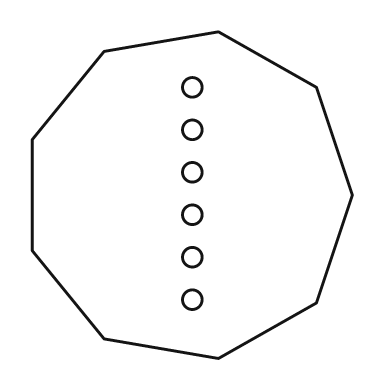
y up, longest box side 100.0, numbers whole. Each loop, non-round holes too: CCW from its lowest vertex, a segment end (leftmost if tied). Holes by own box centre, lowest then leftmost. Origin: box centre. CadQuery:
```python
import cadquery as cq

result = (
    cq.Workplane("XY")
    .moveTo(8.0, -50.0)
    .lineTo(38.0, -33.0)
    .lineTo(49.0, 0.0)
    .lineTo(38.0, 33.0)
    .lineTo(8.0, 50.0)
    .lineTo(-27.0, 44.0)
    .lineTo(-49.0, 17.0)
    .lineTo(-49.0, -17.0)
    .lineTo(-27.0, -44.0)
    .close()
    .moveTo(0.0, -32.0)
    .circle(3.0)
    .moveTo(0.0, -19.0)
    .circle(3.0)
    .moveTo(0.0, -6.0)
    .circle(3.0)
    .moveTo(0.0, 7.0)
    .circle(3.0)
    .moveTo(0.0, 20.0)
    .circle(3.0)
    .moveTo(0.0, 33.0)
    .circle(3.0)
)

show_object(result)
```